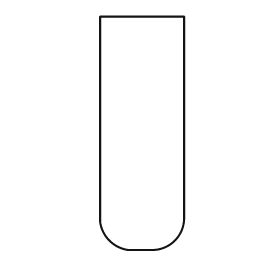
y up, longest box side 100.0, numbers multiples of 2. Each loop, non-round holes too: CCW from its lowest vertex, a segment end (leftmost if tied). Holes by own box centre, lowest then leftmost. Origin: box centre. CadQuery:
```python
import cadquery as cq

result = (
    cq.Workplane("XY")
    .moveTo(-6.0, -50.0)
    .lineTo(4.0, -50.0)
    .threePointArc((14.0, -46.0), (18.0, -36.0))
    .lineTo(18.0, 50.0)
    .lineTo(-18.0, 50.0)
    .lineTo(-18.0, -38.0)
    .threePointArc((-14.0, -46.0), (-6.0, -50.0))
    .close()
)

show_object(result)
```